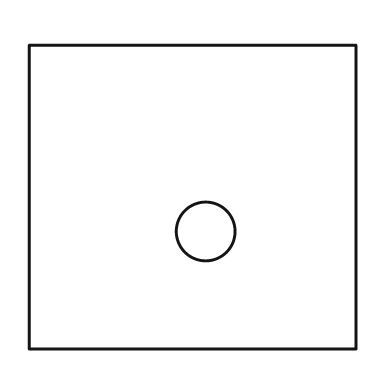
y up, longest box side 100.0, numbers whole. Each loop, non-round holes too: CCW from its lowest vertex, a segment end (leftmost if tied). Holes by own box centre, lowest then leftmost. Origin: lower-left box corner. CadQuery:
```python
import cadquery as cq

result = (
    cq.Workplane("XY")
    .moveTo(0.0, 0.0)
    .lineTo(100.0, 0.0)
    .lineTo(100.0, 93.0)
    .lineTo(0.0, 93.0)
    .close()
    .moveTo(54.0, 36.0)
    .circle(9.0)
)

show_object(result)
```